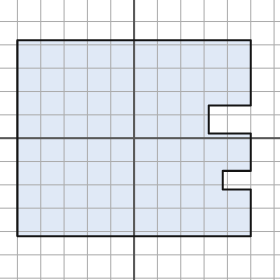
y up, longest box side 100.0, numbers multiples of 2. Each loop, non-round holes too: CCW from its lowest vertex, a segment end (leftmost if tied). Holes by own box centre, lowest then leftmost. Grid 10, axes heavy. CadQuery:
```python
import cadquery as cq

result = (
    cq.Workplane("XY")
    .moveTo(-50.0, -42.0)
    .lineTo(50.0, -42.0)
    .lineTo(50.0, -22.0)
    .lineTo(38.0, -22.0)
    .lineTo(38.0, -14.0)
    .lineTo(50.0, -14.0)
    .lineTo(50.0, 2.0)
    .lineTo(32.0, 2.0)
    .lineTo(32.0, 14.0)
    .lineTo(50.0, 14.0)
    .lineTo(50.0, 42.0)
    .lineTo(-50.0, 42.0)
    .close()
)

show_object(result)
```